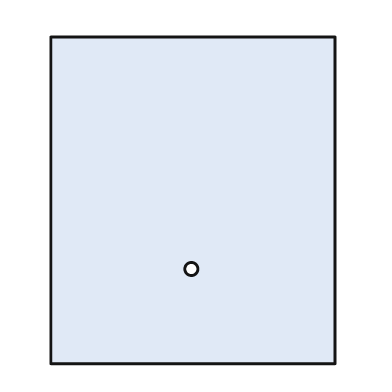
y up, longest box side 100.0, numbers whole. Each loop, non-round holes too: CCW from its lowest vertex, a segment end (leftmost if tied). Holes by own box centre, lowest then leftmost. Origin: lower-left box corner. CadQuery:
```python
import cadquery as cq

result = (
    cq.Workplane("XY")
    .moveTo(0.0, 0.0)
    .lineTo(87.0, 0.0)
    .lineTo(87.0, 100.0)
    .lineTo(0.0, 100.0)
    .close()
    .moveTo(43.0, 29.0)
    .circle(2.0)
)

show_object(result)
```